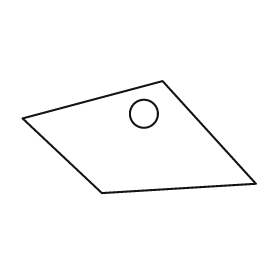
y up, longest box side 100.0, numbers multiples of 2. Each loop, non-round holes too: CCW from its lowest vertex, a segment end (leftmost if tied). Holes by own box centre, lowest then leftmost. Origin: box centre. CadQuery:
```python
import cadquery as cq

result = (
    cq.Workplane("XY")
    .moveTo(-16.0, -24.0)
    .lineTo(50.0, -20.0)
    .lineTo(10.0, 24.0)
    .lineTo(-50.0, 8.0)
    .close()
    .moveTo(2.0, 10.0)
    .circle(6.0)
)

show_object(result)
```